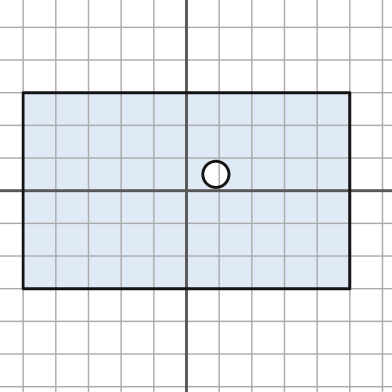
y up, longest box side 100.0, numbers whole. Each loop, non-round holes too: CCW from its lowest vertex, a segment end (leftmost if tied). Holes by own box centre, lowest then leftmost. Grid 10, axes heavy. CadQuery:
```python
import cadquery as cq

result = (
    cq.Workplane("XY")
    .moveTo(-50.0, -30.0)
    .lineTo(50.0, -30.0)
    .lineTo(50.0, 30.0)
    .lineTo(-50.0, 30.0)
    .close()
    .moveTo(9.0, 5.0)
    .circle(4.0)
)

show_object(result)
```